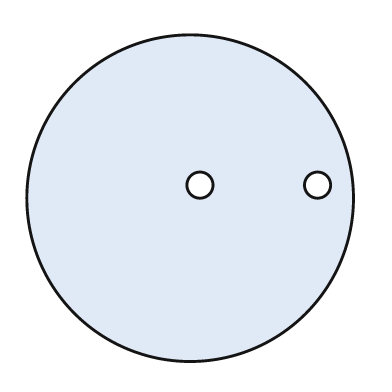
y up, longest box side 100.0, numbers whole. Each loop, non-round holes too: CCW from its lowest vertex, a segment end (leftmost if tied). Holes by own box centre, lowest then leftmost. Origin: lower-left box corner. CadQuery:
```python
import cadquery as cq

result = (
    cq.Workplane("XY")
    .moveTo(50.0, 50.0)
    .circle(50.0)
    .moveTo(53.0, 54.0)
    .circle(4.0)
    .moveTo(89.0, 54.0)
    .circle(4.0)
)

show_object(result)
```